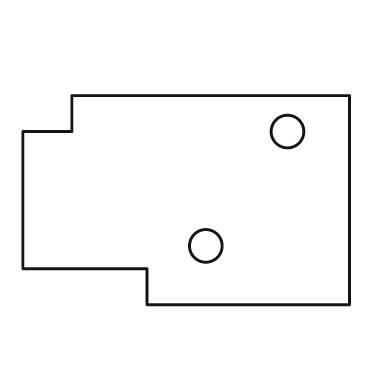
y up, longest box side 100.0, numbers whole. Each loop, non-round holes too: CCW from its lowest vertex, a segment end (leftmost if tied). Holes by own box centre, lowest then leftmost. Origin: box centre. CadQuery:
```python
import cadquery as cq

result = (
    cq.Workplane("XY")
    .moveTo(-12.0, -32.0)
    .lineTo(50.0, -32.0)
    .lineTo(50.0, 32.0)
    .lineTo(-35.0, 32.0)
    .lineTo(-35.0, 21.0)
    .lineTo(-50.0, 21.0)
    .lineTo(-50.0, -21.0)
    .lineTo(-12.0, -21.0)
    .close()
    .moveTo(6.0, -14.0)
    .circle(5.0)
    .moveTo(31.0, 21.0)
    .circle(5.0)
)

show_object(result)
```